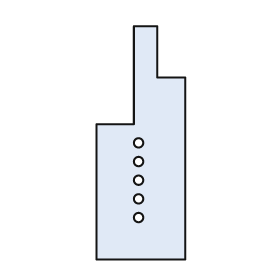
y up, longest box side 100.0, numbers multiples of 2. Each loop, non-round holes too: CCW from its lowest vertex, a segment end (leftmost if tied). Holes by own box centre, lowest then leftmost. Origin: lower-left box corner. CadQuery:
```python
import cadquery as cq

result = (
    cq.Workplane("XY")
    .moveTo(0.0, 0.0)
    .lineTo(38.0, 0.0)
    .lineTo(38.0, 78.0)
    .lineTo(26.0, 78.0)
    .lineTo(26.0, 100.0)
    .lineTo(16.0, 100.0)
    .lineTo(16.0, 58.0)
    .lineTo(0.0, 58.0)
    .close()
    .moveTo(18.0, 18.0)
    .circle(2.0)
    .moveTo(18.0, 26.0)
    .circle(2.0)
    .moveTo(18.0, 34.0)
    .circle(2.0)
    .moveTo(18.0, 42.0)
    .circle(2.0)
    .moveTo(18.0, 50.0)
    .circle(2.0)
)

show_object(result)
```